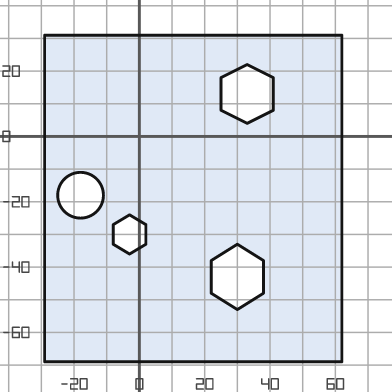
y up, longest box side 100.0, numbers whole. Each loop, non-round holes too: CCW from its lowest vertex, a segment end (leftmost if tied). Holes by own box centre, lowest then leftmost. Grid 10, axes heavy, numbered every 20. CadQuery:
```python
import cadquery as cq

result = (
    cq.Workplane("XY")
    .moveTo(-29.0, -69.0)
    .lineTo(62.0, -69.0)
    .lineTo(62.0, 31.0)
    .lineTo(-29.0, 31.0)
    .close()
    .moveTo(30.0, -53.0)
    .lineTo(38.0, -48.0)
    .lineTo(38.0, -38.0)
    .lineTo(30.0, -33.0)
    .lineTo(22.0, -38.0)
    .lineTo(22.0, -48.0)
    .close()
    .moveTo(-3.0, -36.0)
    .lineTo(2.0, -33.0)
    .lineTo(2.0, -27.0)
    .lineTo(-3.0, -24.0)
    .lineTo(-8.0, -27.0)
    .lineTo(-8.0, -33.0)
    .close()
    .moveTo(-18.0, -18.0)
    .circle(7.0)
    .moveTo(33.0, 4.0)
    .lineTo(41.0, 8.0)
    .lineTo(41.0, 18.0)
    .lineTo(33.0, 22.0)
    .lineTo(25.0, 18.0)
    .lineTo(25.0, 8.0)
    .close()
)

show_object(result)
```